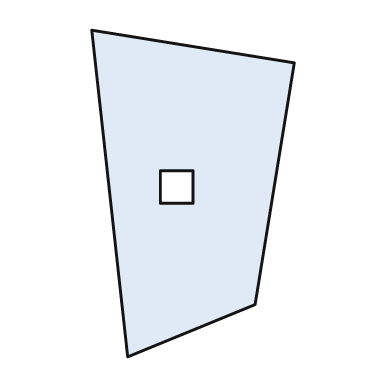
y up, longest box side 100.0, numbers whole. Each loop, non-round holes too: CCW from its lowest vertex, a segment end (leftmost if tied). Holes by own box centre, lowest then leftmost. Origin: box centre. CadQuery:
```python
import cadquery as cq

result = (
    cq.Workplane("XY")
    .moveTo(-20.0, -50.0)
    .lineTo(19.0, -34.0)
    .lineTo(31.0, 40.0)
    .lineTo(-31.0, 50.0)
    .close()
    .moveTo(-10.0, -3.0)
    .lineTo(0.0, -3.0)
    .lineTo(0.0, 7.0)
    .lineTo(-10.0, 7.0)
    .close()
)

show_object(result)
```